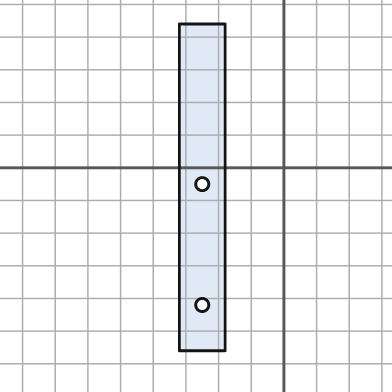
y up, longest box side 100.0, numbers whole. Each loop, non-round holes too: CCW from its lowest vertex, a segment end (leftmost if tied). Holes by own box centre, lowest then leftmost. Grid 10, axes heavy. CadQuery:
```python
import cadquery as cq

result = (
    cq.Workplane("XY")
    .moveTo(-32.0, -56.0)
    .lineTo(-18.0, -56.0)
    .lineTo(-18.0, 44.0)
    .lineTo(-32.0, 44.0)
    .close()
    .moveTo(-25.0, -42.0)
    .circle(2.0)
    .moveTo(-25.0, -5.0)
    .circle(2.0)
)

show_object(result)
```